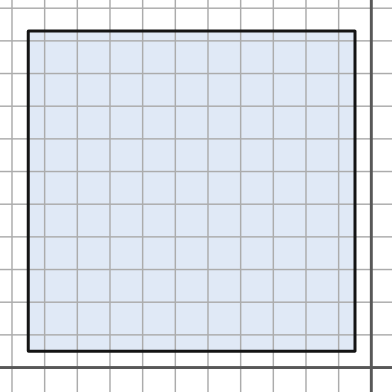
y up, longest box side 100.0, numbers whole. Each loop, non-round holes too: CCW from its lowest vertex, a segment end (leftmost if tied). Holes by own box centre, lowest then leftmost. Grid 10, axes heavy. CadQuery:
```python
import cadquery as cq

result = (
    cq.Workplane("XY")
    .moveTo(-105.0, 5.0)
    .lineTo(-5.0, 5.0)
    .lineTo(-5.0, 103.0)
    .lineTo(-105.0, 103.0)
    .close()
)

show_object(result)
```